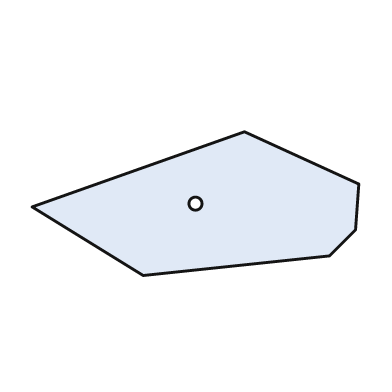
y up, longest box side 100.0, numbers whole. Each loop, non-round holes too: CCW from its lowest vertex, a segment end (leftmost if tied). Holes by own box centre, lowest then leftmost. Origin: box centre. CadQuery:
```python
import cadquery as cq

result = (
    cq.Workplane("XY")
    .moveTo(-16.0, -22.0)
    .lineTo(41.0, -16.0)
    .lineTo(49.0, -8.0)
    .lineTo(50.0, 6.0)
    .lineTo(15.0, 22.0)
    .lineTo(-50.0, -1.0)
    .close()
    .moveTo(0.0, 0.0)
    .circle(2.0)
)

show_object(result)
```